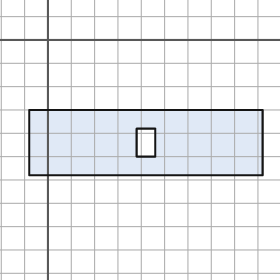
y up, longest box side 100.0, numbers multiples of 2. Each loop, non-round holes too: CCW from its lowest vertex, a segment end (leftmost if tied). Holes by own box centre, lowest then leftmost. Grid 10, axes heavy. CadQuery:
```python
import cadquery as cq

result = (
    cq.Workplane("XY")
    .moveTo(-8.0, -58.0)
    .lineTo(92.0, -58.0)
    .lineTo(92.0, -30.0)
    .lineTo(-8.0, -30.0)
    .close()
    .moveTo(38.0, -50.0)
    .lineTo(46.0, -50.0)
    .lineTo(46.0, -38.0)
    .lineTo(38.0, -38.0)
    .close()
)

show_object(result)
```